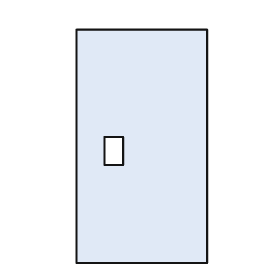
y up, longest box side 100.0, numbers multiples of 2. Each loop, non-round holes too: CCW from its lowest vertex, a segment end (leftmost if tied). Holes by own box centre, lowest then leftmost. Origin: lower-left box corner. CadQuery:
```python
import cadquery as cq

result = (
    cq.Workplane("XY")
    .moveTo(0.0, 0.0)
    .lineTo(56.0, 0.0)
    .lineTo(56.0, 100.0)
    .lineTo(0.0, 100.0)
    .close()
    .moveTo(12.0, 42.0)
    .lineTo(20.0, 42.0)
    .lineTo(20.0, 54.0)
    .lineTo(12.0, 54.0)
    .close()
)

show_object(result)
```